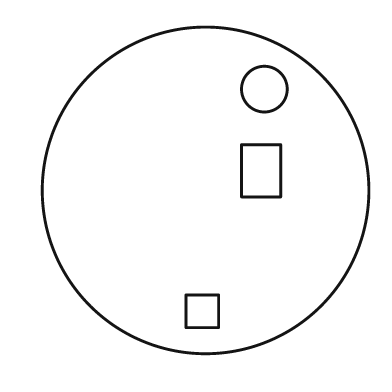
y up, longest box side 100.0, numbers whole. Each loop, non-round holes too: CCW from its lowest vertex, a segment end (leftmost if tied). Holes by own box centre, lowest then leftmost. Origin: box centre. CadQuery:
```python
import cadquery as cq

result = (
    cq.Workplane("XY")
    .moveTo(0.0, 0.0)
    .circle(50.0)
    .moveTo(-6.0, -42.0)
    .lineTo(4.0, -42.0)
    .lineTo(4.0, -32.0)
    .lineTo(-6.0, -32.0)
    .close()
    .moveTo(11.0, -2.0)
    .lineTo(23.0, -2.0)
    .lineTo(23.0, 14.0)
    .lineTo(11.0, 14.0)
    .close()
    .moveTo(18.0, 31.0)
    .circle(7.0)
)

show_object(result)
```